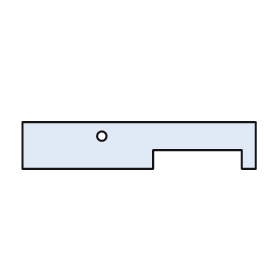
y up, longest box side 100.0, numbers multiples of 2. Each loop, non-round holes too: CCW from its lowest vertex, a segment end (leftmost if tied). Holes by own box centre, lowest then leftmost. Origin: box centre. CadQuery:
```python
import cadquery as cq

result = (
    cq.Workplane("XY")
    .moveTo(-50.0, -10.0)
    .lineTo(6.0, -10.0)
    .lineTo(6.0, -2.0)
    .lineTo(44.0, -2.0)
    .lineTo(44.0, -10.0)
    .lineTo(50.0, -10.0)
    .lineTo(50.0, 10.0)
    .lineTo(-50.0, 10.0)
    .close()
    .moveTo(-16.0, 4.0)
    .circle(2.0)
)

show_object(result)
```